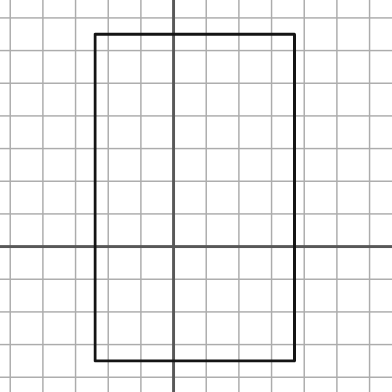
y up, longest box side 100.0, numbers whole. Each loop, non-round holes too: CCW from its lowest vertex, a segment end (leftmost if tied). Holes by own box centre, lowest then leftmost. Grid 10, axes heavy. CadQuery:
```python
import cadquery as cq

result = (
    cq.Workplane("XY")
    .moveTo(-24.0, -35.0)
    .lineTo(37.0, -35.0)
    .lineTo(37.0, 65.0)
    .lineTo(-24.0, 65.0)
    .close()
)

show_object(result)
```